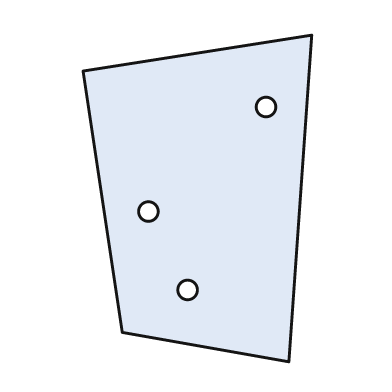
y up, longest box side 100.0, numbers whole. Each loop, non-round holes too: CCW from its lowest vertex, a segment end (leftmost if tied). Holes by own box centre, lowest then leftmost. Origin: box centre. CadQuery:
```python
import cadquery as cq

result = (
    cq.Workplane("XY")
    .moveTo(28.0, -50.0)
    .lineTo(35.0, 50.0)
    .lineTo(-35.0, 39.0)
    .lineTo(-23.0, -41.0)
    .close()
    .moveTo(-3.0, -28.0)
    .circle(3.0)
    .moveTo(-15.0, -4.0)
    .circle(3.0)
    .moveTo(21.0, 28.0)
    .circle(3.0)
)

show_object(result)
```